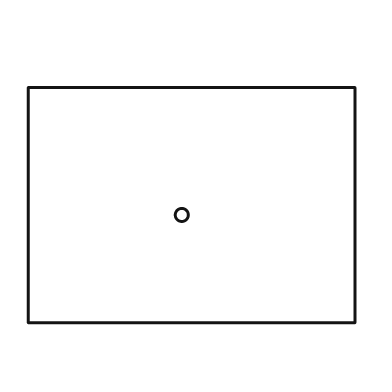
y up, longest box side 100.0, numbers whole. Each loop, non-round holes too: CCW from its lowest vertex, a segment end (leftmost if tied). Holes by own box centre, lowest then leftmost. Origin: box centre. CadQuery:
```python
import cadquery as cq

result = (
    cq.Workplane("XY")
    .moveTo(-50.0, -36.0)
    .lineTo(50.0, -36.0)
    .lineTo(50.0, 36.0)
    .lineTo(-50.0, 36.0)
    .close()
    .moveTo(-3.0, -3.0)
    .circle(2.0)
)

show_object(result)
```